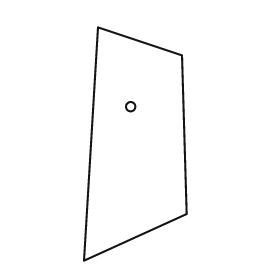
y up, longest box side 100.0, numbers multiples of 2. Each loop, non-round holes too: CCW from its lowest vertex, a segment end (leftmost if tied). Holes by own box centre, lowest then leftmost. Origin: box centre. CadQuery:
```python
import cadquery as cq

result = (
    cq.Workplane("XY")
    .moveTo(-22.0, -50.0)
    .lineTo(22.0, -30.0)
    .lineTo(20.0, 38.0)
    .lineTo(-16.0, 50.0)
    .close()
    .moveTo(-2.0, 16.0)
    .circle(2.0)
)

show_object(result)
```